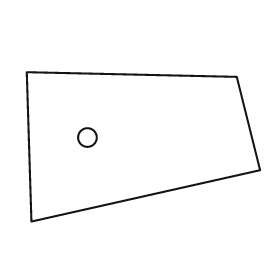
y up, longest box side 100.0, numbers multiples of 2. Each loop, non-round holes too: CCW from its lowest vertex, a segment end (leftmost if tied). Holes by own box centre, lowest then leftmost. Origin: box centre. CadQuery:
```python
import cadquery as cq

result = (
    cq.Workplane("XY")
    .moveTo(-48.0, -32.0)
    .lineTo(50.0, -10.0)
    .lineTo(40.0, 30.0)
    .lineTo(-50.0, 32.0)
    .close()
    .moveTo(-24.0, 4.0)
    .circle(4.0)
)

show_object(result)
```